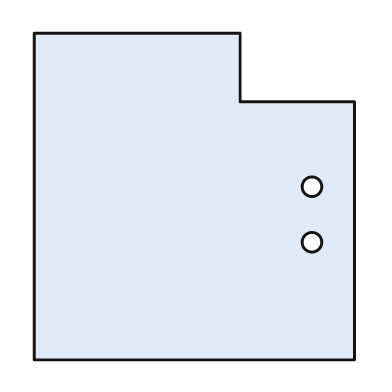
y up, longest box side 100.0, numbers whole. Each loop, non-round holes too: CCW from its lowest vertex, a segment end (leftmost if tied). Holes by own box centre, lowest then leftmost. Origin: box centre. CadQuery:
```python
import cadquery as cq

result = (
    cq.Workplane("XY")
    .moveTo(-49.0, -50.0)
    .lineTo(49.0, -50.0)
    .lineTo(49.0, 29.0)
    .lineTo(14.0, 29.0)
    .lineTo(14.0, 50.0)
    .lineTo(-49.0, 50.0)
    .close()
    .moveTo(36.0, -14.0)
    .circle(3.0)
    .moveTo(36.0, 3.0)
    .circle(3.0)
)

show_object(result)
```